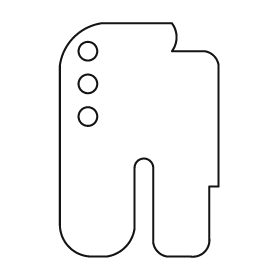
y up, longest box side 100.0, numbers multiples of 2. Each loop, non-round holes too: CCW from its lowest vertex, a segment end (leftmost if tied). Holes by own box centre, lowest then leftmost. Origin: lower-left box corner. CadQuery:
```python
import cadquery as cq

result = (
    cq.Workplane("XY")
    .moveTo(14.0, 0.0)
    .lineTo(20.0, 0.0)
    .threePointArc((28.0, 4.0), (32.0, 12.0))
    .lineTo(32.0, 38.0)
    .threePointArc((36.0, 42.0), (40.0, 38.0))
    .lineTo(40.0, 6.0)
    .threePointArc((42.0, 2.0), (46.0, 0.0))
    .lineTo(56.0, 0.0)
    .threePointArc((62.0, 2.0), (64.0, 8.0))
    .lineTo(64.0, 30.0)
    .lineTo(68.0, 30.0)
    .lineTo(68.0, 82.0)
    .threePointArc((66.0, 86.0), (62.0, 88.0))
    .lineTo(48.0, 88.0)
    .threePointArc((50.0, 94.0), (48.0, 100.0))
    .lineTo(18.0, 100.0)
    .threePointArc((6.0, 94.0), (0.0, 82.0))
    .lineTo(0.0, 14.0)
    .threePointArc((4.0, 4.0), (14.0, 0.0))
    .close()
    .moveTo(12.0, 60.0)
    .circle(4.0)
    .moveTo(12.0, 74.0)
    .circle(4.0)
    .moveTo(12.0, 88.0)
    .circle(4.0)
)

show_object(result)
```